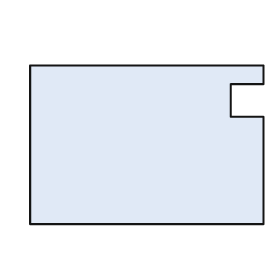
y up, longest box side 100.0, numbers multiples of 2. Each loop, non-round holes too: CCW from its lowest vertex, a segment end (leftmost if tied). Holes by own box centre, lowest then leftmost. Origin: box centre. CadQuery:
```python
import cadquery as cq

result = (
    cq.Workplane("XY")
    .moveTo(-50.0, -34.0)
    .lineTo(50.0, -34.0)
    .lineTo(50.0, 12.0)
    .lineTo(36.0, 12.0)
    .lineTo(36.0, 26.0)
    .lineTo(50.0, 26.0)
    .lineTo(50.0, 34.0)
    .lineTo(-50.0, 34.0)
    .close()
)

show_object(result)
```